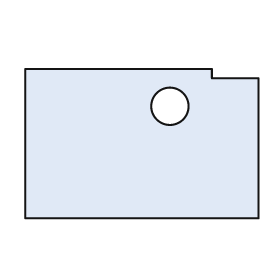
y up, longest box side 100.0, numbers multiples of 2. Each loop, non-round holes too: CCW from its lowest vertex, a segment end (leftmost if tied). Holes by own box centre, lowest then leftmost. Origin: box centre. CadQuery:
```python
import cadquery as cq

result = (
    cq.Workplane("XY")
    .moveTo(-50.0, -32.0)
    .lineTo(50.0, -32.0)
    .lineTo(50.0, 28.0)
    .lineTo(30.0, 28.0)
    .lineTo(30.0, 32.0)
    .lineTo(-50.0, 32.0)
    .close()
    .moveTo(12.0, 16.0)
    .circle(8.0)
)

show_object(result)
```